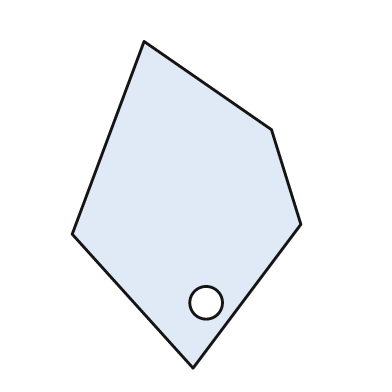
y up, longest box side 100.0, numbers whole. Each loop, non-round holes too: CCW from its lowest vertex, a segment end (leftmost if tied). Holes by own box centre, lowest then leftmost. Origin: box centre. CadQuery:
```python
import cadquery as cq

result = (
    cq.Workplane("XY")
    .moveTo(2.0, -50.0)
    .lineTo(35.0, -6.0)
    .lineTo(26.0, 23.0)
    .lineTo(-13.0, 50.0)
    .lineTo(-35.0, -9.0)
    .close()
    .moveTo(6.0, -30.0)
    .circle(5.0)
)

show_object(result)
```